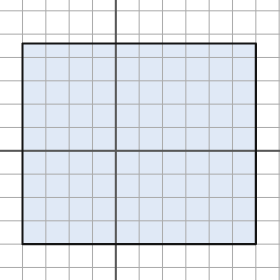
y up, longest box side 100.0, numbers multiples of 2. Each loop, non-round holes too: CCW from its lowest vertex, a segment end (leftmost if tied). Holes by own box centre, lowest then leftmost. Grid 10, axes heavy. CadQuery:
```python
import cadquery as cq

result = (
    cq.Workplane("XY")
    .moveTo(-40.0, -40.0)
    .lineTo(60.0, -40.0)
    .lineTo(60.0, 46.0)
    .lineTo(-40.0, 46.0)
    .close()
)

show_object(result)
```